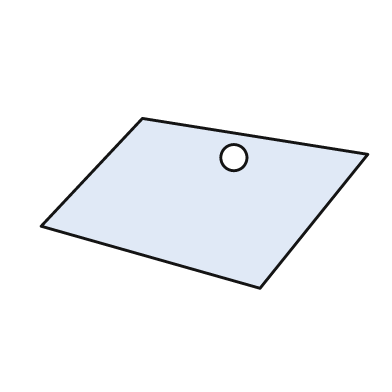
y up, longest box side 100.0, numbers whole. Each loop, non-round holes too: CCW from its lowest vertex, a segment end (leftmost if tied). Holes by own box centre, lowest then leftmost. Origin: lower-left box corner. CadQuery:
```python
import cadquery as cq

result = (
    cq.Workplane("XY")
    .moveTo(67.0, 0.0)
    .lineTo(100.0, 41.0)
    .lineTo(31.0, 52.0)
    .lineTo(0.0, 19.0)
    .close()
    .moveTo(59.0, 40.0)
    .circle(4.0)
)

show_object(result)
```